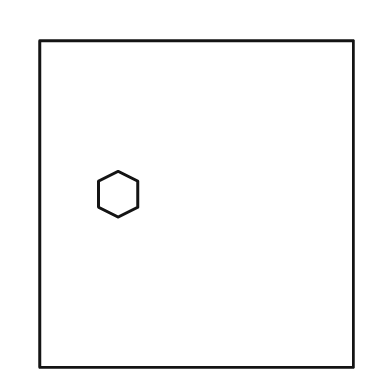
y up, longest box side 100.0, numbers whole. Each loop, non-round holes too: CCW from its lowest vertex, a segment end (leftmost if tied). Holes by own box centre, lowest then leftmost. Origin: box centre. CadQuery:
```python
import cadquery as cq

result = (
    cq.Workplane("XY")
    .moveTo(-48.0, -50.0)
    .lineTo(48.0, -50.0)
    .lineTo(48.0, 50.0)
    .lineTo(-48.0, 50.0)
    .close()
    .moveTo(-24.0, -4.0)
    .lineTo(-18.0, -1.0)
    .lineTo(-18.0, 7.0)
    .lineTo(-24.0, 10.0)
    .lineTo(-30.0, 7.0)
    .lineTo(-30.0, -1.0)
    .close()
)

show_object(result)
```